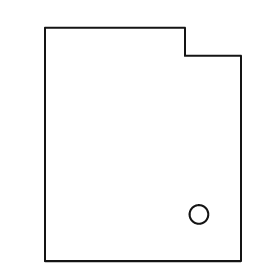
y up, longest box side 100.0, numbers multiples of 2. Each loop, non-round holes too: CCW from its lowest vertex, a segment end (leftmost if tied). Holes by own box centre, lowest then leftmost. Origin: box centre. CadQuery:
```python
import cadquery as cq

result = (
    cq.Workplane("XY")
    .moveTo(-42.0, -50.0)
    .lineTo(42.0, -50.0)
    .lineTo(42.0, 38.0)
    .lineTo(18.0, 38.0)
    .lineTo(18.0, 50.0)
    .lineTo(-42.0, 50.0)
    .close()
    .moveTo(24.0, -30.0)
    .circle(4.0)
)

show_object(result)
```